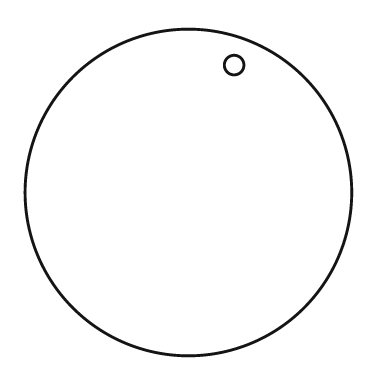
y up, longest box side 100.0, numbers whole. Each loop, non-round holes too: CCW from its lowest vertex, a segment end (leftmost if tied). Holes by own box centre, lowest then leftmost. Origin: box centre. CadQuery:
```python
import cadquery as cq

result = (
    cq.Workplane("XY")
    .moveTo(0.0, 0.0)
    .circle(50.0)
    .moveTo(14.0, 39.0)
    .circle(3.0)
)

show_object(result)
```